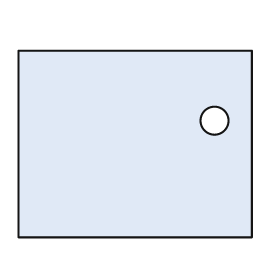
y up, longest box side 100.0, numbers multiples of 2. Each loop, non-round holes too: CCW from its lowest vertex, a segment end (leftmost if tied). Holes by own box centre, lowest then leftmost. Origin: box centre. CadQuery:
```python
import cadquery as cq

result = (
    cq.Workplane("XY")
    .moveTo(-50.0, -40.0)
    .lineTo(50.0, -40.0)
    .lineTo(50.0, 40.0)
    .lineTo(-50.0, 40.0)
    .close()
    .moveTo(34.0, 10.0)
    .circle(6.0)
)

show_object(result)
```